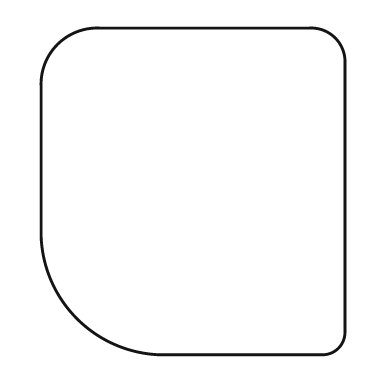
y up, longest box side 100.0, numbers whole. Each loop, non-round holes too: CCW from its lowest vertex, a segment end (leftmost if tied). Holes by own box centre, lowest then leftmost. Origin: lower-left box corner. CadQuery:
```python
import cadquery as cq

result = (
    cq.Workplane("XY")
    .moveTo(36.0, 0.0)
    .lineTo(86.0, 0.0)
    .threePointArc((91.0, 2.0), (93.0, 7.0))
    .lineTo(93.0, 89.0)
    .threePointArc((90.0, 97.0), (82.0, 100.0))
    .lineTo(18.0, 100.0)
    .threePointArc((5.0, 95.0), (0.0, 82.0))
    .lineTo(0.0, 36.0)
    .threePointArc((11.0, 11.0), (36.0, 0.0))
    .close()
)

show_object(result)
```